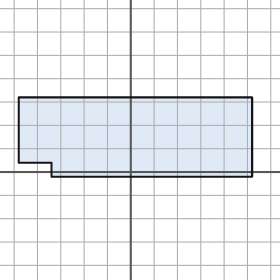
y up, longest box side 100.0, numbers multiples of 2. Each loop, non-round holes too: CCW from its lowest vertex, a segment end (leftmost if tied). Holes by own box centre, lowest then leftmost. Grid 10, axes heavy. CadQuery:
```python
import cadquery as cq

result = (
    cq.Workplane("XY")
    .moveTo(-34.0, -2.0)
    .lineTo(52.0, -2.0)
    .lineTo(52.0, 32.0)
    .lineTo(-48.0, 32.0)
    .lineTo(-48.0, 4.0)
    .lineTo(-34.0, 4.0)
    .close()
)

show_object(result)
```